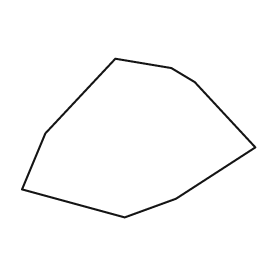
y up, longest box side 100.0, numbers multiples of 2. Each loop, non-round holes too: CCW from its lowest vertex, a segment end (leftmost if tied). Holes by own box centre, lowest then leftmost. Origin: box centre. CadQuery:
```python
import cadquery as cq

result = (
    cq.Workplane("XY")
    .moveTo(-6.0, -34.0)
    .lineTo(16.0, -26.0)
    .lineTo(50.0, -4.0)
    .lineTo(24.0, 24.0)
    .lineTo(14.0, 30.0)
    .lineTo(-10.0, 34.0)
    .lineTo(-40.0, 2.0)
    .lineTo(-50.0, -22.0)
    .close()
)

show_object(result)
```